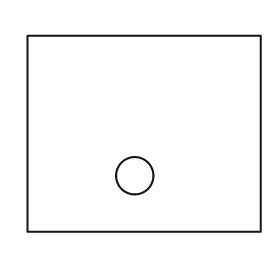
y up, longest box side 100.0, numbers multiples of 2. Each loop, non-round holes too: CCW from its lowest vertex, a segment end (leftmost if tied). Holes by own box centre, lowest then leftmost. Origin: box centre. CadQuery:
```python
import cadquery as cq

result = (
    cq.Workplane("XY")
    .moveTo(-50.0, -42.0)
    .lineTo(50.0, -42.0)
    .lineTo(50.0, 42.0)
    .lineTo(-50.0, 42.0)
    .close()
    .moveTo(-4.0, -18.0)
    .circle(8.0)
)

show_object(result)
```